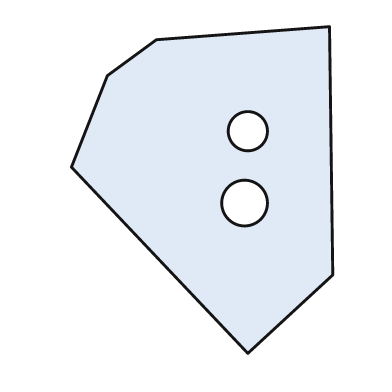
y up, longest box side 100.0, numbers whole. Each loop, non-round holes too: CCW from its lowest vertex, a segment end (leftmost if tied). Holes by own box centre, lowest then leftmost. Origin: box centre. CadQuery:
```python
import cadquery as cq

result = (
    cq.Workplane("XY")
    .moveTo(14.0, -50.0)
    .lineTo(40.0, -26.0)
    .lineTo(39.0, 50.0)
    .lineTo(-14.0, 46.0)
    .lineTo(-29.0, 35.0)
    .lineTo(-40.0, 7.0)
    .close()
    .moveTo(13.0, -4.0)
    .circle(7.0)
    .moveTo(14.0, 18.0)
    .circle(6.0)
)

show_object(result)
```